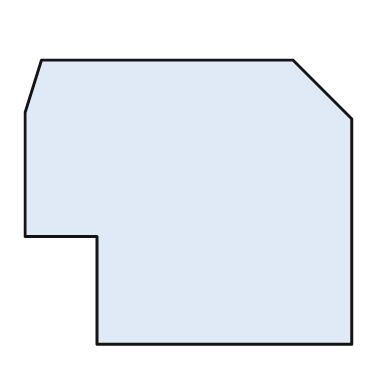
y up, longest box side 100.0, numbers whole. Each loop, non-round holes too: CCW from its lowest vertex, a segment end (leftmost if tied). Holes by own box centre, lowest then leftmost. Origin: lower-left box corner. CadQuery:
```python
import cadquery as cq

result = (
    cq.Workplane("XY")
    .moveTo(22.0, 0.0)
    .lineTo(100.0, 0.0)
    .lineTo(100.0, 69.0)
    .lineTo(82.0, 87.0)
    .lineTo(5.0, 87.0)
    .lineTo(0.0, 71.0)
    .lineTo(0.0, 33.0)
    .lineTo(22.0, 33.0)
    .close()
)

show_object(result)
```